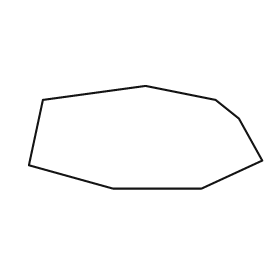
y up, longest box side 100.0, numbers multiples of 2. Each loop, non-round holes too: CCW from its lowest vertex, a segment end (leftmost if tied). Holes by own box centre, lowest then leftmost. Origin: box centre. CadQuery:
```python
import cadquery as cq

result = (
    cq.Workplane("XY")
    .moveTo(-14.0, -22.0)
    .lineTo(24.0, -22.0)
    .lineTo(50.0, -10.0)
    .lineTo(40.0, 8.0)
    .lineTo(30.0, 16.0)
    .lineTo(0.0, 22.0)
    .lineTo(-44.0, 16.0)
    .lineTo(-50.0, -12.0)
    .close()
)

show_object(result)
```